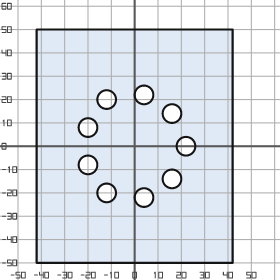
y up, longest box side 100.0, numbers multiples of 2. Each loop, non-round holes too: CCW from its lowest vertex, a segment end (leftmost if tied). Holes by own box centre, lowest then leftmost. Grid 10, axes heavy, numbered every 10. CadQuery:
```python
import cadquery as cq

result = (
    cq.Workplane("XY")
    .moveTo(-42.0, -50.0)
    .lineTo(42.0, -50.0)
    .lineTo(42.0, 50.0)
    .lineTo(-42.0, 50.0)
    .close()
    .moveTo(4.0, -22.0)
    .circle(4.0)
    .moveTo(-12.0, -20.0)
    .circle(4.0)
    .moveTo(16.0, -14.0)
    .circle(4.0)
    .moveTo(-20.0, -8.0)
    .circle(4.0)
    .moveTo(22.0, 0.0)
    .circle(4.0)
    .moveTo(-20.0, 8.0)
    .circle(4.0)
    .moveTo(16.0, 14.0)
    .circle(4.0)
    .moveTo(-12.0, 20.0)
    .circle(4.0)
    .moveTo(4.0, 22.0)
    .circle(4.0)
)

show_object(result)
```